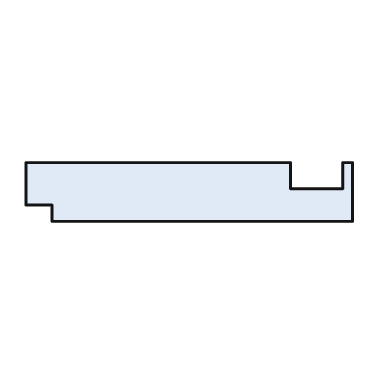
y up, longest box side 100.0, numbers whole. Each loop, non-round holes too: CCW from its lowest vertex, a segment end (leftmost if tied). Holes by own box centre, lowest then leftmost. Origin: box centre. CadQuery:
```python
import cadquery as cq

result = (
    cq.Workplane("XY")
    .moveTo(-42.0, -9.0)
    .lineTo(50.0, -9.0)
    .lineTo(50.0, 9.0)
    .lineTo(47.0, 9.0)
    .lineTo(47.0, 1.0)
    .lineTo(31.0, 1.0)
    .lineTo(31.0, 9.0)
    .lineTo(-50.0, 9.0)
    .lineTo(-50.0, -4.0)
    .lineTo(-42.0, -4.0)
    .close()
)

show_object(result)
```